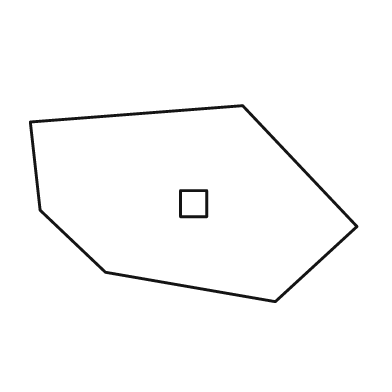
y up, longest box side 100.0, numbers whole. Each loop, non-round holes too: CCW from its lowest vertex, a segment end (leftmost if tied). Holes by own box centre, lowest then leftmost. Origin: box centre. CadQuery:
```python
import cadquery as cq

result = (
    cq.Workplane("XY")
    .moveTo(25.0, -30.0)
    .lineTo(50.0, -7.0)
    .lineTo(15.0, 30.0)
    .lineTo(-50.0, 25.0)
    .lineTo(-47.0, -2.0)
    .lineTo(-27.0, -21.0)
    .close()
    .moveTo(-4.0, -4.0)
    .lineTo(4.0, -4.0)
    .lineTo(4.0, 4.0)
    .lineTo(-4.0, 4.0)
    .close()
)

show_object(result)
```